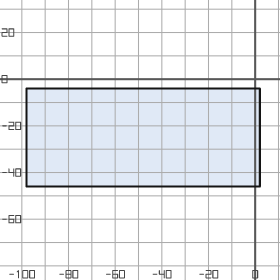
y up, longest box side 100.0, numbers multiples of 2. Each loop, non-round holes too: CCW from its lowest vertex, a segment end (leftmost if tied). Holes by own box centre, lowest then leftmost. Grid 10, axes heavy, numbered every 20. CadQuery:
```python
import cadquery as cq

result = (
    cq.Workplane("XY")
    .moveTo(-98.0, -46.0)
    .lineTo(2.0, -46.0)
    .lineTo(2.0, -4.0)
    .lineTo(-98.0, -4.0)
    .close()
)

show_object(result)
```